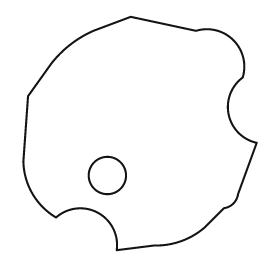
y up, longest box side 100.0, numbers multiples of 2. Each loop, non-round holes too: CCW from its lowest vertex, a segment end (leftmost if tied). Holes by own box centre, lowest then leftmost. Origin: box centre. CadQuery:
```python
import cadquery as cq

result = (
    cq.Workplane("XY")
    .moveTo(-10.0, -50.0)
    .lineTo(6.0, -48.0)
    .threePointArc((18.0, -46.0), (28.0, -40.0))
    .lineTo(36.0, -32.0)
    .threePointArc((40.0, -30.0), (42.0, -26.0))
    .lineTo(50.0, -4.0)
    .threePointArc((38.0, 8.0), (44.0, 24.0))
    .threePointArc((40.0, 40.0), (24.0, 44.0))
    .lineTo(-4.0, 50.0)
    .lineTo(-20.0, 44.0)
    .threePointArc((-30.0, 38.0), (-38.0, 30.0))
    .lineTo(-48.0, 16.0)
    .lineTo(-50.0, -12.0)
    .threePointArc((-46.0, -26.0), (-36.0, -36.0))
    .threePointArc((-18.0, -34.0), (-10.0, -50.0))
    .close()
    .moveTo(-14.0, -18.0)
    .circle(8.0)
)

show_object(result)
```